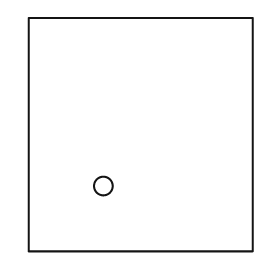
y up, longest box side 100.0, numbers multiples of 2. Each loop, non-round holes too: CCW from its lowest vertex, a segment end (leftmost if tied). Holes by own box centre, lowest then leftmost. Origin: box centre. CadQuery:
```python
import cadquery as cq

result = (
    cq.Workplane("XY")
    .moveTo(-48.0, -50.0)
    .lineTo(48.0, -50.0)
    .lineTo(48.0, 50.0)
    .lineTo(-48.0, 50.0)
    .close()
    .moveTo(-16.0, -22.0)
    .circle(4.0)
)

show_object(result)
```